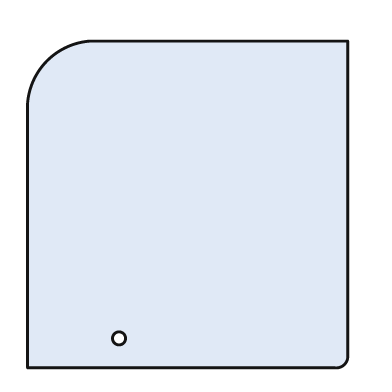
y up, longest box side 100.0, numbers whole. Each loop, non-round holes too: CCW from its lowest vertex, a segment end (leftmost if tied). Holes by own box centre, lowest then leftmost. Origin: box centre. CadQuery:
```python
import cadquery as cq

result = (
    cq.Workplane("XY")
    .moveTo(-49.0, -50.0)
    .lineTo(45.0, -50.0)
    .threePointArc((48.0, -49.0), (49.0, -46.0))
    .lineTo(49.0, 50.0)
    .lineTo(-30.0, 50.0)
    .threePointArc((-43.0, 44.0), (-49.0, 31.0))
    .close()
    .moveTo(-21.0, -41.0)
    .circle(2.0)
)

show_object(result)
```